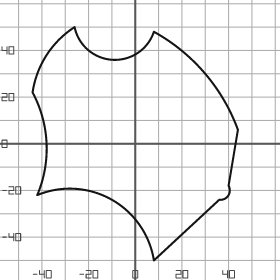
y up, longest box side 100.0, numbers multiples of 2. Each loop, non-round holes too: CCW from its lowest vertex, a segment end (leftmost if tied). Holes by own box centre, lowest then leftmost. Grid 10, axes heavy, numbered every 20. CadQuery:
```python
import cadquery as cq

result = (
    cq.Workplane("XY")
    .moveTo(8.0, -50.0)
    .lineTo(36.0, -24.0)
    .threePointArc((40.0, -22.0), (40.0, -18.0))
    .lineTo(44.0, 6.0)
    .threePointArc((30.0, 30.0), (8.0, 48.0))
    .threePointArc((-10.0, 36.0), (-26.0, 50.0))
    .threePointArc((-38.0, 38.0), (-44.0, 22.0))
    .threePointArc((-38.0, 0.0), (-42.0, -22.0))
    .threePointArc((-10.0, -24.0), (8.0, -50.0))
    .close()
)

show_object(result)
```